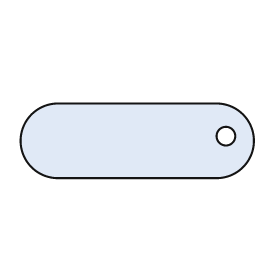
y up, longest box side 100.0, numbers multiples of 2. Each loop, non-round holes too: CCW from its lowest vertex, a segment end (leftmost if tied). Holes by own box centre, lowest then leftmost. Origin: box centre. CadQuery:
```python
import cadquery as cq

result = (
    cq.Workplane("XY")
    .moveTo(-34.0, -16.0)
    .lineTo(34.0, -16.0)
    .threePointArc((50.0, 0.0), (34.0, 16.0))
    .lineTo(-34.0, 16.0)
    .threePointArc((-50.0, 0.0), (-34.0, -16.0))
    .close()
    .moveTo(38.0, 2.0)
    .circle(4.0)
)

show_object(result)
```